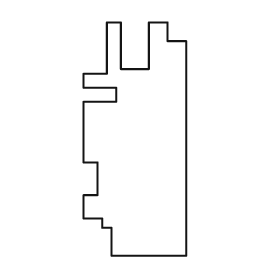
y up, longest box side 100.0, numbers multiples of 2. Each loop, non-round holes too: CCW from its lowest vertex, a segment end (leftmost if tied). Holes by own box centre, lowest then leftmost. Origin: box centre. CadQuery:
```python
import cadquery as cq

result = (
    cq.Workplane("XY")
    .moveTo(-10.0, -50.0)
    .lineTo(22.0, -50.0)
    .lineTo(22.0, 42.0)
    .lineTo(14.0, 42.0)
    .lineTo(14.0, 50.0)
    .lineTo(6.0, 50.0)
    .lineTo(6.0, 30.0)
    .lineTo(-6.0, 30.0)
    .lineTo(-6.0, 50.0)
    .lineTo(-12.0, 50.0)
    .lineTo(-12.0, 28.0)
    .lineTo(-22.0, 28.0)
    .lineTo(-22.0, 22.0)
    .lineTo(-8.0, 22.0)
    .lineTo(-8.0, 16.0)
    .lineTo(-22.0, 16.0)
    .lineTo(-22.0, -10.0)
    .lineTo(-16.0, -10.0)
    .lineTo(-16.0, -24.0)
    .lineTo(-22.0, -24.0)
    .lineTo(-22.0, -34.0)
    .lineTo(-14.0, -34.0)
    .lineTo(-14.0, -38.0)
    .lineTo(-10.0, -38.0)
    .close()
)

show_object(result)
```